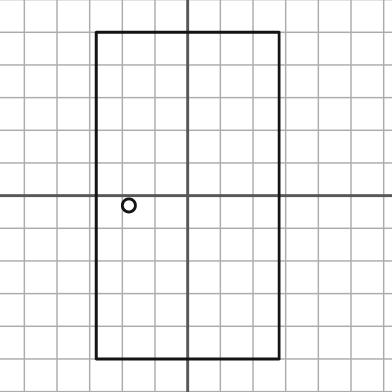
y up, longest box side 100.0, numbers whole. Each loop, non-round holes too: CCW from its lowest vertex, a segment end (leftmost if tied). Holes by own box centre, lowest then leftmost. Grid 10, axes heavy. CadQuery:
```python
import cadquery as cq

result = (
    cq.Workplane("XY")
    .moveTo(-28.0, -50.0)
    .lineTo(28.0, -50.0)
    .lineTo(28.0, 50.0)
    .lineTo(-28.0, 50.0)
    .close()
    .moveTo(-18.0, -3.0)
    .circle(2.0)
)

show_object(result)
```